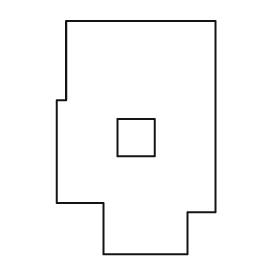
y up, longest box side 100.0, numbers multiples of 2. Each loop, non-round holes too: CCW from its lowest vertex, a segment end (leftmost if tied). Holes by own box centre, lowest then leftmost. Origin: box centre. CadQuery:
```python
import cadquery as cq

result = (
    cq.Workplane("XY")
    .moveTo(-14.0, -50.0)
    .lineTo(22.0, -50.0)
    .lineTo(22.0, -32.0)
    .lineTo(34.0, -32.0)
    .lineTo(34.0, 50.0)
    .lineTo(-30.0, 50.0)
    .lineTo(-30.0, 16.0)
    .lineTo(-34.0, 16.0)
    .lineTo(-34.0, -28.0)
    .lineTo(-14.0, -28.0)
    .close()
    .moveTo(-8.0, -8.0)
    .lineTo(8.0, -8.0)
    .lineTo(8.0, 8.0)
    .lineTo(-8.0, 8.0)
    .close()
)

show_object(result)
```